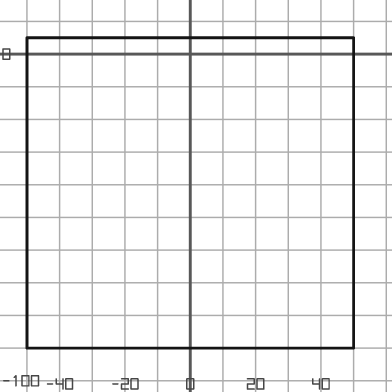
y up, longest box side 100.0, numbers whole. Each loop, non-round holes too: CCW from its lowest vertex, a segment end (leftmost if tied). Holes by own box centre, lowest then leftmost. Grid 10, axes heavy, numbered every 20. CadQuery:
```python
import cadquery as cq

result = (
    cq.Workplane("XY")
    .moveTo(-50.0, -90.0)
    .lineTo(50.0, -90.0)
    .lineTo(50.0, 5.0)
    .lineTo(-50.0, 5.0)
    .close()
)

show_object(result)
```